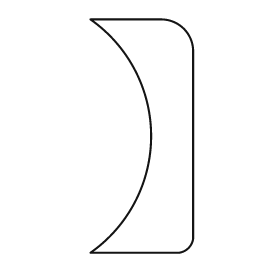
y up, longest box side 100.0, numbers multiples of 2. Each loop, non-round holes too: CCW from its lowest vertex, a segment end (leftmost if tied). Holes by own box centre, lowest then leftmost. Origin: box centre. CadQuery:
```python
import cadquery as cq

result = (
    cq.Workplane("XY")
    .moveTo(-22.0, -50.0)
    .lineTo(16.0, -50.0)
    .threePointArc((20.0, -48.0), (22.0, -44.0))
    .lineTo(22.0, 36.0)
    .threePointArc((18.0, 46.0), (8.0, 50.0))
    .lineTo(-22.0, 50.0)
    .threePointArc((4.0, 0.0), (-22.0, -50.0))
    .close()
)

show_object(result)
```